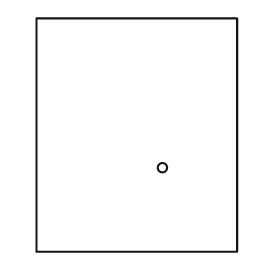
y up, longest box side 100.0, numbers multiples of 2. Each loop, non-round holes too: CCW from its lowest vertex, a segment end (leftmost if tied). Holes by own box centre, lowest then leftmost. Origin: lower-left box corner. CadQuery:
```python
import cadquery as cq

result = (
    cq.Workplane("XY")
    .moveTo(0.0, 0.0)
    .lineTo(86.0, 0.0)
    .lineTo(86.0, 100.0)
    .lineTo(0.0, 100.0)
    .close()
    .moveTo(54.0, 36.0)
    .circle(2.0)
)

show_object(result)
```